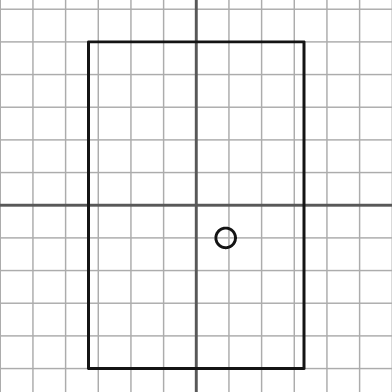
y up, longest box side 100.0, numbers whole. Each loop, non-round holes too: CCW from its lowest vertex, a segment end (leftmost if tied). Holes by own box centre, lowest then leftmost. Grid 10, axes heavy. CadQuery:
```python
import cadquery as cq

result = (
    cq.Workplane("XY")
    .moveTo(-33.0, -50.0)
    .lineTo(33.0, -50.0)
    .lineTo(33.0, 50.0)
    .lineTo(-33.0, 50.0)
    .close()
    .moveTo(9.0, -10.0)
    .circle(3.0)
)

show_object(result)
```